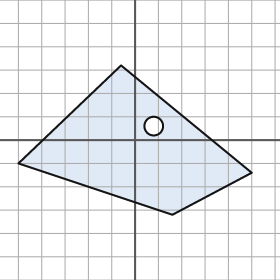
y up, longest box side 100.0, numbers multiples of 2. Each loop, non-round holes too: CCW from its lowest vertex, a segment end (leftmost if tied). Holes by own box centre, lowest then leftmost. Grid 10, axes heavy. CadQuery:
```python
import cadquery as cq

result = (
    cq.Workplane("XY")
    .moveTo(16.0, -32.0)
    .lineTo(50.0, -14.0)
    .lineTo(-6.0, 32.0)
    .lineTo(-50.0, -10.0)
    .close()
    .moveTo(8.0, 6.0)
    .circle(4.0)
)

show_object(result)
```